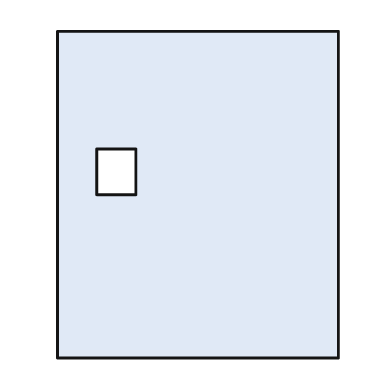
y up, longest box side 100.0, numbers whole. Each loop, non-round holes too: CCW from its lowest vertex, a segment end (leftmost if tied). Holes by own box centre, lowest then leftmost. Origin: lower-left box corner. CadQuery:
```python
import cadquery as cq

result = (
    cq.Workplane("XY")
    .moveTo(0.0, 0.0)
    .lineTo(86.0, 0.0)
    .lineTo(86.0, 100.0)
    .lineTo(0.0, 100.0)
    .close()
    .moveTo(12.0, 50.0)
    .lineTo(24.0, 50.0)
    .lineTo(24.0, 64.0)
    .lineTo(12.0, 64.0)
    .close()
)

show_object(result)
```